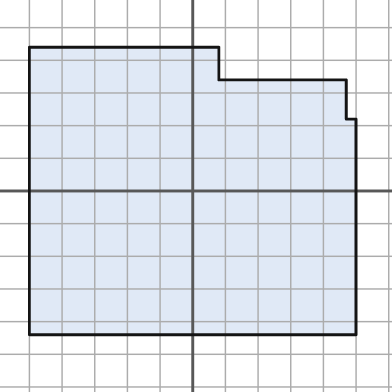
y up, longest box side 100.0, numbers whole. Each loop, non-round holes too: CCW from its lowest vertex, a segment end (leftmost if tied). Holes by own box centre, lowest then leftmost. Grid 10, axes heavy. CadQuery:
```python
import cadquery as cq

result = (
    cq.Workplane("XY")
    .moveTo(-50.0, -44.0)
    .lineTo(50.0, -44.0)
    .lineTo(50.0, 22.0)
    .lineTo(47.0, 22.0)
    .lineTo(47.0, 34.0)
    .lineTo(8.0, 34.0)
    .lineTo(8.0, 44.0)
    .lineTo(-50.0, 44.0)
    .close()
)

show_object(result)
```